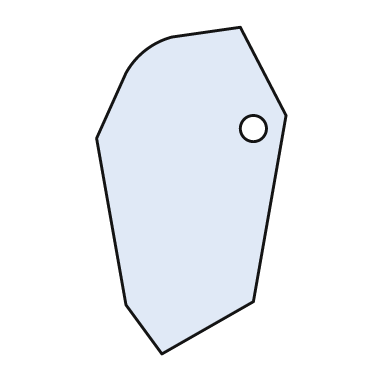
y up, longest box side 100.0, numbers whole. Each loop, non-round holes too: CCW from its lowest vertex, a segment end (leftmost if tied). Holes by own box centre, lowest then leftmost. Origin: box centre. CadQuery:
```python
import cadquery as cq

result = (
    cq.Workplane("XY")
    .moveTo(-9.0, -50.0)
    .lineTo(19.0, -34.0)
    .lineTo(29.0, 23.0)
    .lineTo(15.0, 50.0)
    .lineTo(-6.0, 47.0)
    .threePointArc((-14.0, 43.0), (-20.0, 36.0))
    .lineTo(-29.0, 16.0)
    .lineTo(-20.0, -35.0)
    .close()
    .moveTo(19.0, 19.0)
    .circle(4.0)
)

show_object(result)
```